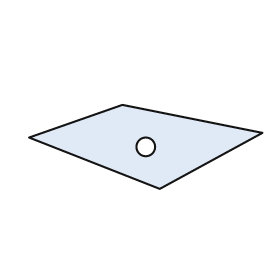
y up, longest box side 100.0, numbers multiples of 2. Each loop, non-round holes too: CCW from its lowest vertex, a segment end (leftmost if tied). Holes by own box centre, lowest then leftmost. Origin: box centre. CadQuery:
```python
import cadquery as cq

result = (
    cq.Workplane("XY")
    .moveTo(6.0, -18.0)
    .lineTo(50.0, 6.0)
    .lineTo(-10.0, 18.0)
    .lineTo(-50.0, 4.0)
    .close()
    .moveTo(0.0, 0.0)
    .circle(4.0)
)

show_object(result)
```